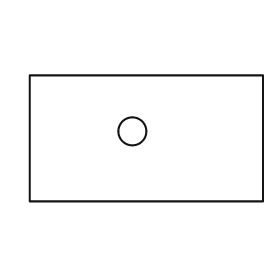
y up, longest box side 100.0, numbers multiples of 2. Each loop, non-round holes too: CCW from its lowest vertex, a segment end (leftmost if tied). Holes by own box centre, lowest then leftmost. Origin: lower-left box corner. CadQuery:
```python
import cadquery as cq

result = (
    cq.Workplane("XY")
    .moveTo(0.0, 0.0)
    .lineTo(100.0, 0.0)
    .lineTo(100.0, 54.0)
    .lineTo(0.0, 54.0)
    .close()
    .moveTo(44.0, 30.0)
    .circle(6.0)
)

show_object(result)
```